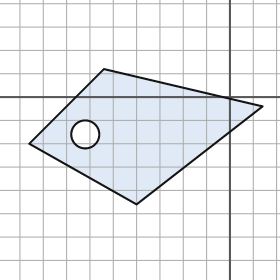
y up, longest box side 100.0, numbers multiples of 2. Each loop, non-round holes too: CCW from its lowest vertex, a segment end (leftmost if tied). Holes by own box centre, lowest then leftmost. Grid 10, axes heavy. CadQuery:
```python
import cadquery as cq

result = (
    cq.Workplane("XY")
    .moveTo(-40.0, -46.0)
    .lineTo(14.0, -4.0)
    .lineTo(-54.0, 12.0)
    .lineTo(-86.0, -20.0)
    .close()
    .moveTo(-62.0, -16.0)
    .circle(6.0)
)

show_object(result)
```